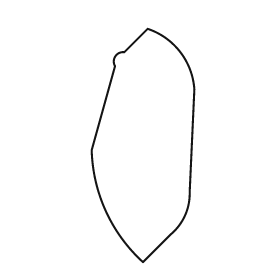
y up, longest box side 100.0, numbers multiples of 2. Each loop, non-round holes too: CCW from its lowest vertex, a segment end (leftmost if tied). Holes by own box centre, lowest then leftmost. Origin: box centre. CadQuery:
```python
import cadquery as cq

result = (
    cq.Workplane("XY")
    .moveTo(0.0, -50.0)
    .lineTo(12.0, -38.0)
    .threePointArc((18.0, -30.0), (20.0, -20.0))
    .lineTo(22.0, 24.0)
    .threePointArc((16.0, 40.0), (2.0, 50.0))
    .lineTo(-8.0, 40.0)
    .threePointArc((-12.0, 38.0), (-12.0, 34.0))
    .lineTo(-22.0, -2.0)
    .threePointArc((-16.0, -28.0), (0.0, -50.0))
    .close()
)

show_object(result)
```